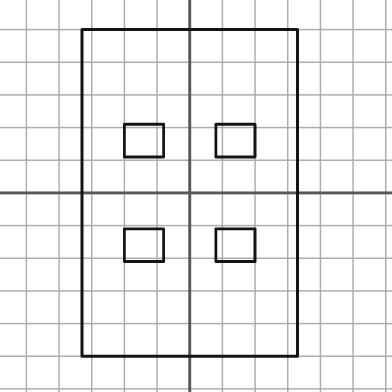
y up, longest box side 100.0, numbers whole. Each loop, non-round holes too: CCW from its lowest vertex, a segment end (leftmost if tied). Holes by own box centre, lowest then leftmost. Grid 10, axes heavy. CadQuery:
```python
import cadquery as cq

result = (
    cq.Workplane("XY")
    .moveTo(-33.0, -50.0)
    .lineTo(33.0, -50.0)
    .lineTo(33.0, 50.0)
    .lineTo(-33.0, 50.0)
    .close()
    .moveTo(-20.0, -21.0)
    .lineTo(-8.0, -21.0)
    .lineTo(-8.0, -11.0)
    .lineTo(-20.0, -11.0)
    .close()
    .moveTo(8.0, -21.0)
    .lineTo(20.0, -21.0)
    .lineTo(20.0, -11.0)
    .lineTo(8.0, -11.0)
    .close()
    .moveTo(-20.0, 11.0)
    .lineTo(-8.0, 11.0)
    .lineTo(-8.0, 21.0)
    .lineTo(-20.0, 21.0)
    .close()
    .moveTo(8.0, 11.0)
    .lineTo(20.0, 11.0)
    .lineTo(20.0, 21.0)
    .lineTo(8.0, 21.0)
    .close()
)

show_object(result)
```